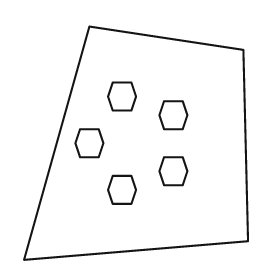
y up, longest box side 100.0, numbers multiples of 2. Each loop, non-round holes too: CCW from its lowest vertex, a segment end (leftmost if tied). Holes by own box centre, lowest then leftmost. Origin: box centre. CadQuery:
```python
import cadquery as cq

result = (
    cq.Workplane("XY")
    .moveTo(-48.0, -50.0)
    .lineTo(48.0, -42.0)
    .lineTo(46.0, 40.0)
    .lineTo(-20.0, 50.0)
    .close()
    .moveTo(-10.0, -26.0)
    .lineTo(-2.0, -26.0)
    .lineTo(0.0, -20.0)
    .lineTo(-2.0, -14.0)
    .lineTo(-10.0, -14.0)
    .lineTo(-12.0, -20.0)
    .close()
    .moveTo(12.0, -18.0)
    .lineTo(20.0, -18.0)
    .lineTo(22.0, -12.0)
    .lineTo(20.0, -6.0)
    .lineTo(12.0, -6.0)
    .lineTo(10.0, -12.0)
    .close()
    .moveTo(-24.0, -6.0)
    .lineTo(-16.0, -6.0)
    .lineTo(-14.0, 0.0)
    .lineTo(-16.0, 6.0)
    .lineTo(-24.0, 6.0)
    .lineTo(-26.0, 0.0)
    .close()
    .moveTo(12.0, 6.0)
    .lineTo(20.0, 6.0)
    .lineTo(22.0, 12.0)
    .lineTo(20.0, 18.0)
    .lineTo(12.0, 18.0)
    .lineTo(10.0, 12.0)
    .close()
    .moveTo(-10.0, 14.0)
    .lineTo(-2.0, 14.0)
    .lineTo(0.0, 20.0)
    .lineTo(-2.0, 26.0)
    .lineTo(-10.0, 26.0)
    .lineTo(-12.0, 20.0)
    .close()
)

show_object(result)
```